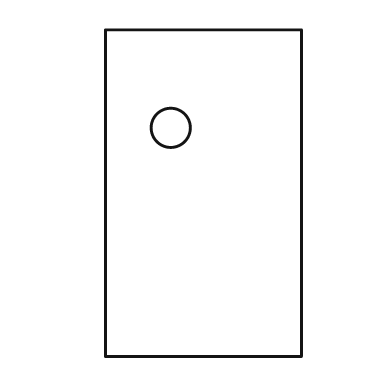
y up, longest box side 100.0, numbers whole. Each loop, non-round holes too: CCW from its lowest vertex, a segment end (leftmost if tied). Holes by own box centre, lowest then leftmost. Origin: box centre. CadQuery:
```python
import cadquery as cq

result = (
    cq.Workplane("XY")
    .moveTo(-30.0, -50.0)
    .lineTo(30.0, -50.0)
    .lineTo(30.0, 50.0)
    .lineTo(-30.0, 50.0)
    .close()
    .moveTo(-10.0, 20.0)
    .circle(6.0)
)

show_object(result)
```